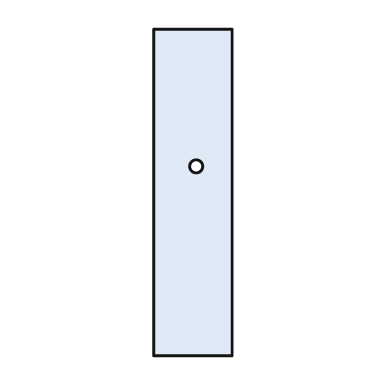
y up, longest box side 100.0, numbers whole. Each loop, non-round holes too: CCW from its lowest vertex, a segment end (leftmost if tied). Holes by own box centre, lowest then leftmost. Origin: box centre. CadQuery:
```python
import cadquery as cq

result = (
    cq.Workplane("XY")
    .moveTo(-12.0, -50.0)
    .lineTo(12.0, -50.0)
    .lineTo(12.0, 50.0)
    .lineTo(-12.0, 50.0)
    .close()
    .moveTo(1.0, 8.0)
    .circle(2.0)
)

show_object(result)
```